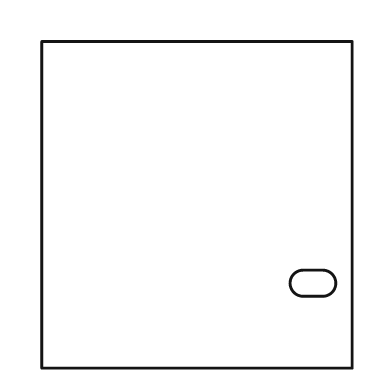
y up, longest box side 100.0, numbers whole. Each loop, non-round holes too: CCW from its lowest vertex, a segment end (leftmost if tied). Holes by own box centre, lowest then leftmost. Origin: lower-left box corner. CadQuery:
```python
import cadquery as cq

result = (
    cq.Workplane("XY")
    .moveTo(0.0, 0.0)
    .lineTo(95.0, 0.0)
    .lineTo(95.0, 100.0)
    .lineTo(0.0, 100.0)
    .close()
    .moveTo(80.0, 22.0)
    .lineTo(86.0, 22.0)
    .threePointArc((90.0, 26.0), (86.0, 30.0))
    .lineTo(80.0, 30.0)
    .threePointArc((76.0, 26.0), (80.0, 22.0))
    .close()
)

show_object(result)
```